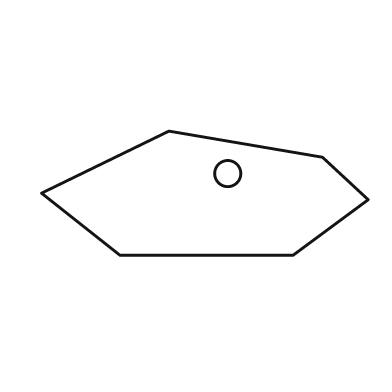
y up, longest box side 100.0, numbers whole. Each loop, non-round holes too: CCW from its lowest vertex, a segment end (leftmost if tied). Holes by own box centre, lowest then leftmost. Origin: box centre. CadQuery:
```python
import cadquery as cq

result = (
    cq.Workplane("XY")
    .moveTo(-26.0, -19.0)
    .lineTo(27.0, -19.0)
    .lineTo(50.0, -2.0)
    .lineTo(36.0, 11.0)
    .lineTo(-11.0, 19.0)
    .lineTo(-50.0, 0.0)
    .close()
    .moveTo(7.0, 6.0)
    .circle(4.0)
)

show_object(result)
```